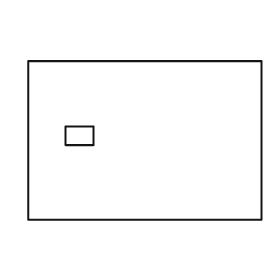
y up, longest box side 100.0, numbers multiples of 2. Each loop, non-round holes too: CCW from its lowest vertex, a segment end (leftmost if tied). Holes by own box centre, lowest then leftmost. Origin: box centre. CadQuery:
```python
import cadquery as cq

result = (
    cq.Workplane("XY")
    .moveTo(-50.0, -34.0)
    .lineTo(50.0, -34.0)
    .lineTo(50.0, 34.0)
    .lineTo(-50.0, 34.0)
    .close()
    .moveTo(-34.0, -2.0)
    .lineTo(-22.0, -2.0)
    .lineTo(-22.0, 6.0)
    .lineTo(-34.0, 6.0)
    .close()
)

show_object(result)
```